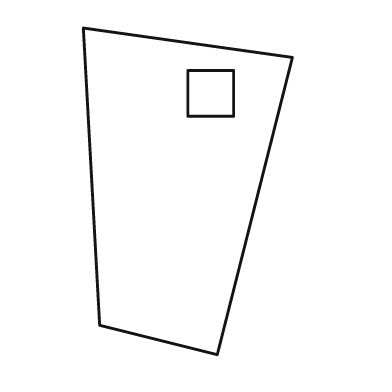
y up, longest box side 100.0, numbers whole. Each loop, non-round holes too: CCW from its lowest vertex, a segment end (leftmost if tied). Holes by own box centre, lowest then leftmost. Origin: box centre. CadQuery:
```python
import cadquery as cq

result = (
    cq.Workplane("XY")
    .moveTo(9.0, -50.0)
    .lineTo(32.0, 41.0)
    .lineTo(-32.0, 50.0)
    .lineTo(-27.0, -41.0)
    .close()
    .moveTo(0.0, 23.0)
    .lineTo(14.0, 23.0)
    .lineTo(14.0, 37.0)
    .lineTo(0.0, 37.0)
    .close()
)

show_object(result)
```